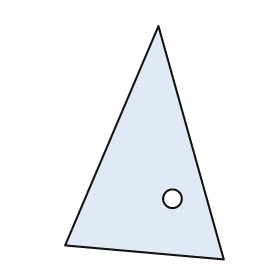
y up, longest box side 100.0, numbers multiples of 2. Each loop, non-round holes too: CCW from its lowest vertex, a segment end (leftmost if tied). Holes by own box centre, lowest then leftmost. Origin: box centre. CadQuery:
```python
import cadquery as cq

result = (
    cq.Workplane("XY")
    .moveTo(34.0, -50.0)
    .lineTo(6.0, 50.0)
    .lineTo(-34.0, -44.0)
    .close()
    .moveTo(12.0, -24.0)
    .circle(4.0)
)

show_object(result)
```